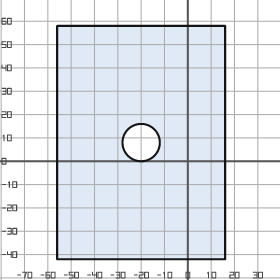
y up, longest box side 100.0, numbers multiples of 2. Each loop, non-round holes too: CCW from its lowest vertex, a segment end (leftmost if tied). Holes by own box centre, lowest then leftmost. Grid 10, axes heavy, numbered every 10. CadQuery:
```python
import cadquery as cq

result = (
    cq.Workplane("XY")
    .moveTo(-56.0, -42.0)
    .lineTo(16.0, -42.0)
    .lineTo(16.0, 58.0)
    .lineTo(-56.0, 58.0)
    .close()
    .moveTo(-20.0, 8.0)
    .circle(8.0)
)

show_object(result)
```